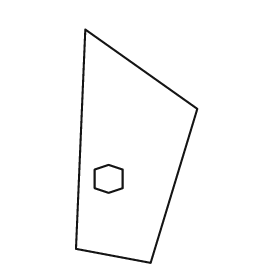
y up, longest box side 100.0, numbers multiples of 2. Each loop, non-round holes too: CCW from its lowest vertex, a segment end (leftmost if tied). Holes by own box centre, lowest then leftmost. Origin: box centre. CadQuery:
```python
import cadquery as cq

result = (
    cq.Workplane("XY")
    .moveTo(6.0, -50.0)
    .lineTo(26.0, 16.0)
    .lineTo(-22.0, 50.0)
    .lineTo(-26.0, -44.0)
    .close()
    .moveTo(-12.0, -20.0)
    .lineTo(-6.0, -18.0)
    .lineTo(-6.0, -10.0)
    .lineTo(-12.0, -8.0)
    .lineTo(-18.0, -10.0)
    .lineTo(-18.0, -18.0)
    .close()
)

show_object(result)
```